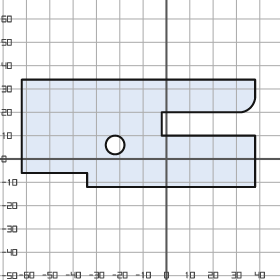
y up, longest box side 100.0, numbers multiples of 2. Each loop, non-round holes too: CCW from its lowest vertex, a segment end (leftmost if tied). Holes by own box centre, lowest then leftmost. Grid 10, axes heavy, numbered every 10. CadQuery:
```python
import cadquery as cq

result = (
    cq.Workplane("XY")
    .moveTo(-34.0, -12.0)
    .lineTo(38.0, -12.0)
    .lineTo(38.0, 10.0)
    .lineTo(-2.0, 10.0)
    .lineTo(-2.0, 20.0)
    .lineTo(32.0, 20.0)
    .threePointArc((36.0, 22.0), (38.0, 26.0))
    .lineTo(38.0, 34.0)
    .lineTo(-62.0, 34.0)
    .lineTo(-62.0, -6.0)
    .lineTo(-34.0, -6.0)
    .close()
    .moveTo(-22.0, 6.0)
    .circle(4.0)
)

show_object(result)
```